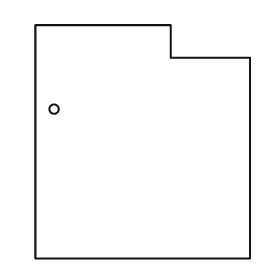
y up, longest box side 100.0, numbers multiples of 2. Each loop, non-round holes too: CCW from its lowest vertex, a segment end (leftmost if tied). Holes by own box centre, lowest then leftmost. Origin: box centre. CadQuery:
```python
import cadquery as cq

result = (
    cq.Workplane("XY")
    .moveTo(-46.0, -50.0)
    .lineTo(46.0, -50.0)
    .lineTo(46.0, 36.0)
    .lineTo(12.0, 36.0)
    .lineTo(12.0, 50.0)
    .lineTo(-46.0, 50.0)
    .close()
    .moveTo(-38.0, 14.0)
    .circle(2.0)
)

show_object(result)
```